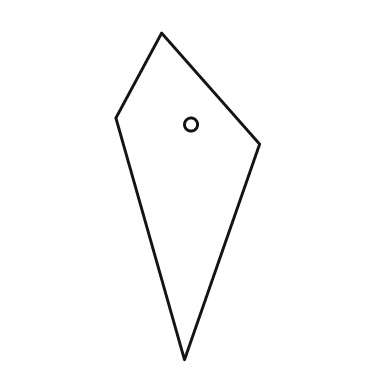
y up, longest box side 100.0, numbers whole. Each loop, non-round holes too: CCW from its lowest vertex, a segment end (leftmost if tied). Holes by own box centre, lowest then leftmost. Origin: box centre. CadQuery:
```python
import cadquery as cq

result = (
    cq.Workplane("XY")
    .moveTo(-1.0, -50.0)
    .lineTo(22.0, 16.0)
    .lineTo(-8.0, 50.0)
    .lineTo(-22.0, 24.0)
    .close()
    .moveTo(1.0, 22.0)
    .circle(2.0)
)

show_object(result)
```